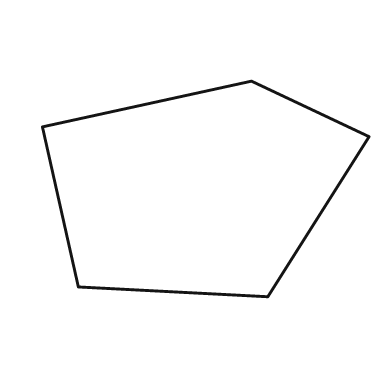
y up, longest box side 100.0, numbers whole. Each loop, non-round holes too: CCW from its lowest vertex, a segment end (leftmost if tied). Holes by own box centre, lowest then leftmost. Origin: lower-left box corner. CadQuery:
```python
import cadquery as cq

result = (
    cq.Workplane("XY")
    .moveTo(69.0, 0.0)
    .lineTo(100.0, 49.0)
    .lineTo(64.0, 66.0)
    .lineTo(0.0, 52.0)
    .lineTo(11.0, 3.0)
    .close()
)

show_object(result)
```